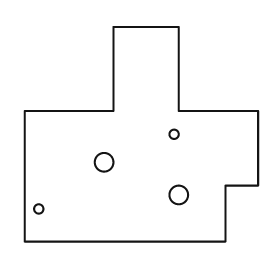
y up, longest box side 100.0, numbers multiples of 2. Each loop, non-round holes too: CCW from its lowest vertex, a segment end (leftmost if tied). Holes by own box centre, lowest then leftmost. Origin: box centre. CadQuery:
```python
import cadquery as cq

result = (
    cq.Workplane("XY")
    .moveTo(-50.0, -46.0)
    .lineTo(36.0, -46.0)
    .lineTo(36.0, -22.0)
    .lineTo(50.0, -22.0)
    .lineTo(50.0, 10.0)
    .lineTo(16.0, 10.0)
    .lineTo(16.0, 46.0)
    .lineTo(-12.0, 46.0)
    .lineTo(-12.0, 10.0)
    .lineTo(-50.0, 10.0)
    .close()
    .moveTo(-44.0, -32.0)
    .circle(2.0)
    .moveTo(16.0, -26.0)
    .circle(4.0)
    .moveTo(-16.0, -12.0)
    .circle(4.0)
    .moveTo(14.0, 0.0)
    .circle(2.0)
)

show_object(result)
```